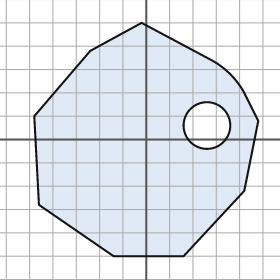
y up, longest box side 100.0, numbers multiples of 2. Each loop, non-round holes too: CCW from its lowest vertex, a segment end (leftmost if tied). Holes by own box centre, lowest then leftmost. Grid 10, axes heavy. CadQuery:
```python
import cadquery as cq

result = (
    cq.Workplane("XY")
    .moveTo(-14.0, -50.0)
    .lineTo(16.0, -50.0)
    .lineTo(42.0, -22.0)
    .lineTo(48.0, 8.0)
    .lineTo(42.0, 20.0)
    .threePointArc((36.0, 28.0), (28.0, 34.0))
    .lineTo(-2.0, 50.0)
    .lineTo(-24.0, 38.0)
    .lineTo(-48.0, 10.0)
    .lineTo(-46.0, -28.0)
    .close()
    .moveTo(26.0, 6.0)
    .circle(10.0)
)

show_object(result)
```